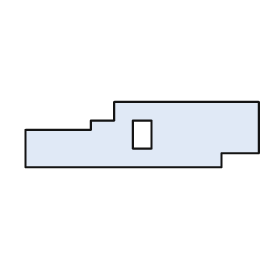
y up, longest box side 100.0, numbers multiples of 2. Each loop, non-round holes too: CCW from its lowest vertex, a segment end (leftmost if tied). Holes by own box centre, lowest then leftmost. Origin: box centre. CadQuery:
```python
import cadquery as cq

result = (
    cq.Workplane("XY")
    .moveTo(-50.0, -14.0)
    .lineTo(34.0, -14.0)
    .lineTo(34.0, -8.0)
    .lineTo(50.0, -8.0)
    .lineTo(50.0, 14.0)
    .lineTo(-12.0, 14.0)
    .lineTo(-12.0, 6.0)
    .lineTo(-22.0, 6.0)
    .lineTo(-22.0, 2.0)
    .lineTo(-50.0, 2.0)
    .close()
    .moveTo(-4.0, -6.0)
    .lineTo(4.0, -6.0)
    .lineTo(4.0, 6.0)
    .lineTo(-4.0, 6.0)
    .close()
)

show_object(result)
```